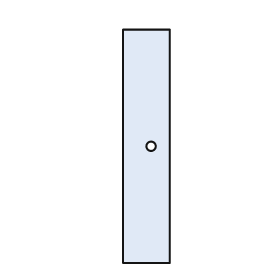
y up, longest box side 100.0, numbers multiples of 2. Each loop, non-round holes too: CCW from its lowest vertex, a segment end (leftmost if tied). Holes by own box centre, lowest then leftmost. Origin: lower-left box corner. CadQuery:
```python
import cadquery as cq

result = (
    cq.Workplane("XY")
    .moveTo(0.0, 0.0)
    .lineTo(20.0, 0.0)
    .lineTo(20.0, 100.0)
    .lineTo(0.0, 100.0)
    .close()
    .moveTo(12.0, 50.0)
    .circle(2.0)
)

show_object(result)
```